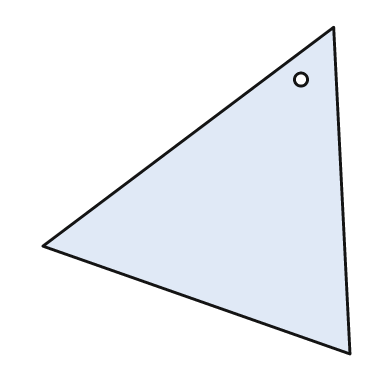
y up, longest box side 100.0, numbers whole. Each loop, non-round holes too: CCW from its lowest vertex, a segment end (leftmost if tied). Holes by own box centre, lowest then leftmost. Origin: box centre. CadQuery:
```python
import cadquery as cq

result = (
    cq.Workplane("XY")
    .moveTo(47.0, -50.0)
    .lineTo(42.0, 50.0)
    .lineTo(-47.0, -17.0)
    .close()
    .moveTo(32.0, 34.0)
    .circle(2.0)
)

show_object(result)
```